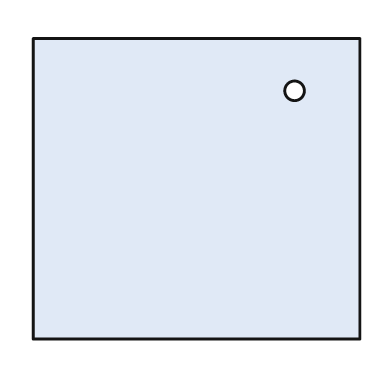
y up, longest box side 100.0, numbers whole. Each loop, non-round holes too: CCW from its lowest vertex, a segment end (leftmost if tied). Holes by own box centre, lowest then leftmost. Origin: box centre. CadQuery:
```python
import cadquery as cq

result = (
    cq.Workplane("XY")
    .moveTo(-50.0, -46.0)
    .lineTo(50.0, -46.0)
    .lineTo(50.0, 46.0)
    .lineTo(-50.0, 46.0)
    .close()
    .moveTo(30.0, 30.0)
    .circle(3.0)
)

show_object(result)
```